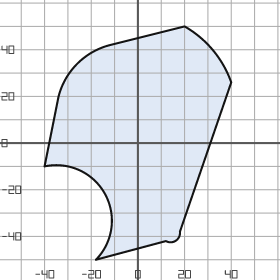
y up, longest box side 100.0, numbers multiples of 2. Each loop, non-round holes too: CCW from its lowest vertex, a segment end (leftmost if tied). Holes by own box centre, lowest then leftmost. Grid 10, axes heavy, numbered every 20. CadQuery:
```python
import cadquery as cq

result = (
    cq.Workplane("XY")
    .moveTo(-18.0, -50.0)
    .lineTo(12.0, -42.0)
    .threePointArc((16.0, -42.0), (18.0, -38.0))
    .lineTo(40.0, 26.0)
    .threePointArc((32.0, 40.0), (20.0, 50.0))
    .lineTo(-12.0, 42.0)
    .threePointArc((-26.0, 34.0), (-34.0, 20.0))
    .lineTo(-40.0, -10.0)
    .threePointArc((-14.0, -22.0), (-18.0, -50.0))
    .close()
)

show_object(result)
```